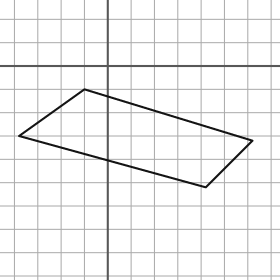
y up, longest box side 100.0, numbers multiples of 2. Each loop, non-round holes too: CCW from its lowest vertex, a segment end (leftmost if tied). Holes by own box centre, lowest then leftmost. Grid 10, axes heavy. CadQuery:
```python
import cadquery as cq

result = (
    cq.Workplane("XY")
    .moveTo(42.0, -52.0)
    .lineTo(62.0, -32.0)
    .lineTo(-10.0, -10.0)
    .lineTo(-38.0, -30.0)
    .close()
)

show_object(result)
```